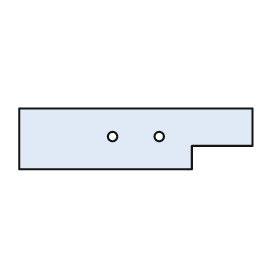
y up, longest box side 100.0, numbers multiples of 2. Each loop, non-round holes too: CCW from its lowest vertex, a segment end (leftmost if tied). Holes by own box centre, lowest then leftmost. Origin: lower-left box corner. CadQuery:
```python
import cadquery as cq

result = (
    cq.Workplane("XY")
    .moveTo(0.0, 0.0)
    .lineTo(74.0, 0.0)
    .lineTo(74.0, 10.0)
    .lineTo(100.0, 10.0)
    .lineTo(100.0, 26.0)
    .lineTo(0.0, 26.0)
    .close()
    .moveTo(40.0, 14.0)
    .circle(2.0)
    .moveTo(60.0, 14.0)
    .circle(2.0)
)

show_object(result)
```